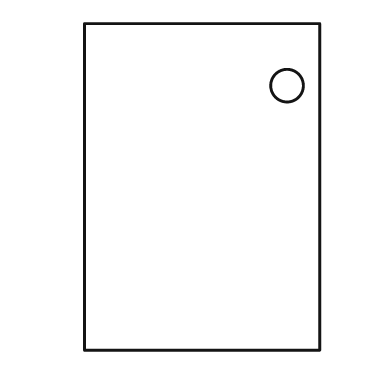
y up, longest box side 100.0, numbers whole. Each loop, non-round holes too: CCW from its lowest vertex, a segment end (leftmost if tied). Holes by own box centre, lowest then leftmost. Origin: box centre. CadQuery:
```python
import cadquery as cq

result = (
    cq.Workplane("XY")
    .moveTo(-36.0, -50.0)
    .lineTo(36.0, -50.0)
    .lineTo(36.0, 50.0)
    .lineTo(-36.0, 50.0)
    .close()
    .moveTo(26.0, 31.0)
    .circle(5.0)
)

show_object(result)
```